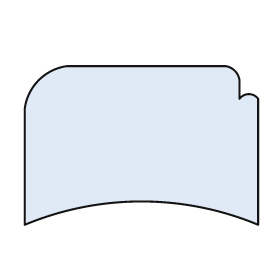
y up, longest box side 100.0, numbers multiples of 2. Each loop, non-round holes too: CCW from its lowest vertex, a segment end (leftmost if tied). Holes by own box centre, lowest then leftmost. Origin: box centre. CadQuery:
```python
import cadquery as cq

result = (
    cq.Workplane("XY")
    .moveTo(-50.0, -34.0)
    .threePointArc((0.0, -24.0), (50.0, -34.0))
    .lineTo(50.0, 20.0)
    .threePointArc((46.0, 22.0), (42.0, 20.0))
    .lineTo(42.0, 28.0)
    .threePointArc((40.0, 32.0), (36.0, 34.0))
    .lineTo(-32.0, 34.0)
    .threePointArc((-44.0, 28.0), (-50.0, 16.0))
    .close()
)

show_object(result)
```